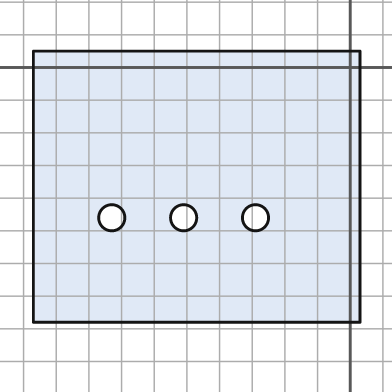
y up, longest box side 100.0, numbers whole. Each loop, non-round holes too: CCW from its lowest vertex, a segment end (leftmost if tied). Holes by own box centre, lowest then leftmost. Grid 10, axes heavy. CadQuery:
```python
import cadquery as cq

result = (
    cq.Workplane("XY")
    .moveTo(-97.0, -78.0)
    .lineTo(3.0, -78.0)
    .lineTo(3.0, 5.0)
    .lineTo(-97.0, 5.0)
    .close()
    .moveTo(-73.0, -46.0)
    .circle(4.0)
    .moveTo(-51.0, -46.0)
    .circle(4.0)
    .moveTo(-29.0, -46.0)
    .circle(4.0)
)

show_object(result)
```